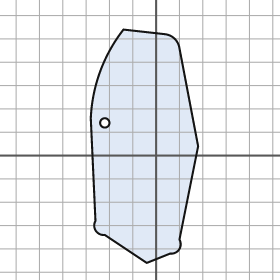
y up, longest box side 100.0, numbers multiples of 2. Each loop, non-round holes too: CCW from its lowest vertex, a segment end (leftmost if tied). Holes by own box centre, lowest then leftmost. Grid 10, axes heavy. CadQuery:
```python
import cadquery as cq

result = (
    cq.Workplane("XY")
    .moveTo(-4.0, -46.0)
    .lineTo(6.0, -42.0)
    .threePointArc((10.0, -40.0), (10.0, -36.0))
    .lineTo(18.0, 4.0)
    .lineTo(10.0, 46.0)
    .threePointArc((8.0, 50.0), (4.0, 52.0))
    .lineTo(-14.0, 54.0)
    .threePointArc((-24.0, 36.0), (-28.0, 16.0))
    .lineTo(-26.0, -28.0)
    .threePointArc((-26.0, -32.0), (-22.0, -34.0))
    .close()
    .moveTo(-22.0, 14.0)
    .circle(2.0)
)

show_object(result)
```